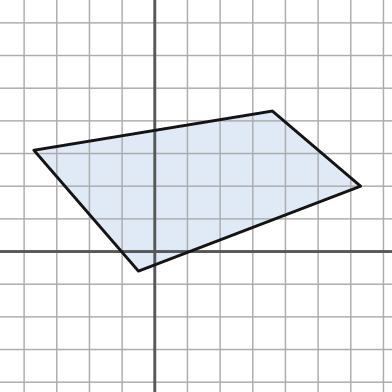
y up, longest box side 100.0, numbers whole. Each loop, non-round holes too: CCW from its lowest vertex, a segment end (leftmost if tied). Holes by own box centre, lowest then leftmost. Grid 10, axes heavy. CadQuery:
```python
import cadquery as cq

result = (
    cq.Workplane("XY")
    .moveTo(-5.0, -6.0)
    .lineTo(63.0, 20.0)
    .lineTo(36.0, 43.0)
    .lineTo(-37.0, 31.0)
    .close()
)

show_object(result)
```